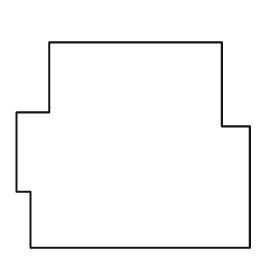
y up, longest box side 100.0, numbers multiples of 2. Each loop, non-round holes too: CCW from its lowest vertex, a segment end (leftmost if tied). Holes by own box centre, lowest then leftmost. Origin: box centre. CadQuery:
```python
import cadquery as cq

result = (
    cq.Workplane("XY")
    .moveTo(-44.0, -44.0)
    .lineTo(50.0, -44.0)
    .lineTo(50.0, 8.0)
    .lineTo(38.0, 8.0)
    .lineTo(38.0, 44.0)
    .lineTo(-36.0, 44.0)
    .lineTo(-36.0, 14.0)
    .lineTo(-50.0, 14.0)
    .lineTo(-50.0, -20.0)
    .lineTo(-44.0, -20.0)
    .close()
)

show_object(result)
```